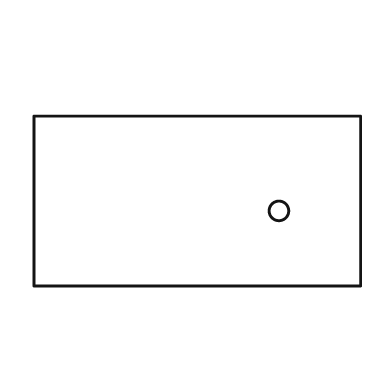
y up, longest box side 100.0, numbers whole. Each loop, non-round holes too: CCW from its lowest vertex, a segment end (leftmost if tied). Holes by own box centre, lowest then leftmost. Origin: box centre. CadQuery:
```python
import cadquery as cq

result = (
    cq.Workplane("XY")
    .moveTo(-50.0, -26.0)
    .lineTo(50.0, -26.0)
    .lineTo(50.0, 26.0)
    .lineTo(-50.0, 26.0)
    .close()
    .moveTo(25.0, -3.0)
    .circle(3.0)
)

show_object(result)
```